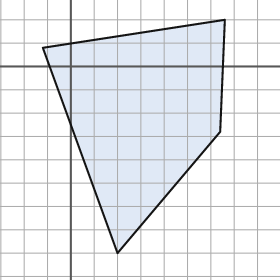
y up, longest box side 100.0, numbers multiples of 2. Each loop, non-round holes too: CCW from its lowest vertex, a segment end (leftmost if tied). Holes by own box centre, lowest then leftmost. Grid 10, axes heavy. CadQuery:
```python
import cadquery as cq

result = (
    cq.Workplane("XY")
    .moveTo(20.0, -80.0)
    .lineTo(64.0, -28.0)
    .lineTo(66.0, 20.0)
    .lineTo(-12.0, 8.0)
    .close()
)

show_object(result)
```